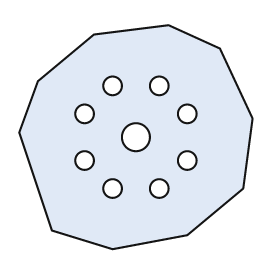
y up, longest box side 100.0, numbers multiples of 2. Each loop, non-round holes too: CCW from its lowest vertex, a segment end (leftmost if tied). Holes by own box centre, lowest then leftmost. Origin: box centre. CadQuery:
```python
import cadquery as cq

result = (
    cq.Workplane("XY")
    .moveTo(-10.0, -48.0)
    .lineTo(22.0, -42.0)
    .lineTo(46.0, -22.0)
    .lineTo(50.0, 8.0)
    .lineTo(36.0, 38.0)
    .lineTo(14.0, 48.0)
    .lineTo(-18.0, 44.0)
    .lineTo(-42.0, 24.0)
    .lineTo(-50.0, 2.0)
    .lineTo(-36.0, -40.0)
    .close()
    .moveTo(-10.0, -22.0)
    .circle(4.0)
    .moveTo(10.0, -22.0)
    .circle(4.0)
    .moveTo(-22.0, -10.0)
    .circle(4.0)
    .moveTo(22.0, -10.0)
    .circle(4.0)
    .moveTo(0.0, 0.0)
    .circle(6.0)
    .moveTo(-22.0, 10.0)
    .circle(4.0)
    .moveTo(22.0, 10.0)
    .circle(4.0)
    .moveTo(-10.0, 22.0)
    .circle(4.0)
    .moveTo(10.0, 22.0)
    .circle(4.0)
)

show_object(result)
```